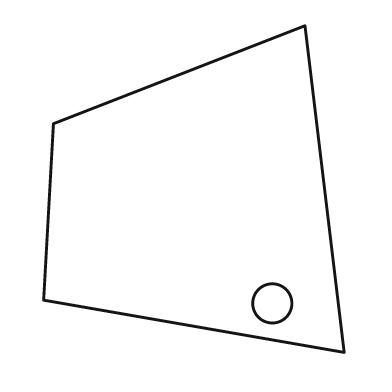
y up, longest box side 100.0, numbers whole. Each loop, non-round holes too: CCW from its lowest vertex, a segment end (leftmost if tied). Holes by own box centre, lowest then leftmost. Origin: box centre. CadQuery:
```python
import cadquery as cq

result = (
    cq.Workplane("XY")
    .moveTo(46.0, -50.0)
    .lineTo(34.0, 50.0)
    .lineTo(-43.0, 20.0)
    .lineTo(-46.0, -34.0)
    .close()
    .moveTo(24.0, -35.0)
    .circle(6.0)
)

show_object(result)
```